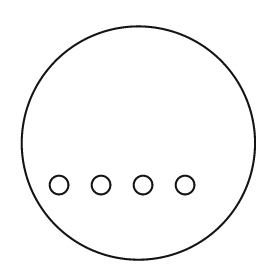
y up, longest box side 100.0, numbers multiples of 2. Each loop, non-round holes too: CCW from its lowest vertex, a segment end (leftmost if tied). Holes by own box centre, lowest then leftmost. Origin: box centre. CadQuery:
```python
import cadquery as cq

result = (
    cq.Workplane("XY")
    .moveTo(0.0, 0.0)
    .circle(50.0)
    .moveTo(-34.0, -18.0)
    .circle(4.0)
    .moveTo(-16.0, -18.0)
    .circle(4.0)
    .moveTo(2.0, -18.0)
    .circle(4.0)
    .moveTo(20.0, -18.0)
    .circle(4.0)
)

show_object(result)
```